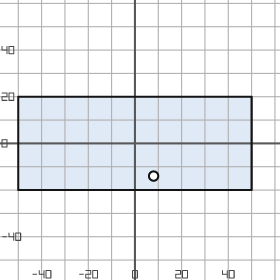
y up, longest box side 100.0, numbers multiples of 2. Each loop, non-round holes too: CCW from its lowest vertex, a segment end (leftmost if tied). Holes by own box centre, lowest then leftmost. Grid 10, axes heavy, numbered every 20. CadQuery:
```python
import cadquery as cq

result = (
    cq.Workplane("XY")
    .moveTo(-50.0, -20.0)
    .lineTo(50.0, -20.0)
    .lineTo(50.0, 20.0)
    .lineTo(-50.0, 20.0)
    .close()
    .moveTo(8.0, -14.0)
    .circle(2.0)
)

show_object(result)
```